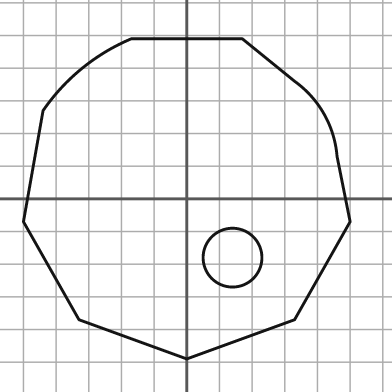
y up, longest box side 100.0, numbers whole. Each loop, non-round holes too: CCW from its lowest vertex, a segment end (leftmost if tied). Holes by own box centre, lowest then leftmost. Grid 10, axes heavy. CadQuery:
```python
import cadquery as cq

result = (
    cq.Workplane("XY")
    .moveTo(0.0, -49.0)
    .lineTo(33.0, -37.0)
    .lineTo(50.0, -7.0)
    .lineTo(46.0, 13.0)
    .threePointArc((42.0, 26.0), (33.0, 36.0))
    .lineTo(17.0, 49.0)
    .lineTo(-17.0, 49.0)
    .threePointArc((-32.0, 40.0), (-44.0, 27.0))
    .lineTo(-50.0, -7.0)
    .lineTo(-33.0, -37.0)
    .close()
    .moveTo(14.0, -18.0)
    .circle(9.0)
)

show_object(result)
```